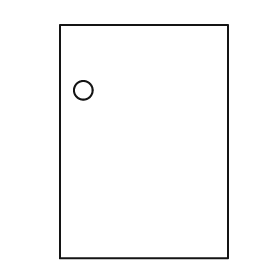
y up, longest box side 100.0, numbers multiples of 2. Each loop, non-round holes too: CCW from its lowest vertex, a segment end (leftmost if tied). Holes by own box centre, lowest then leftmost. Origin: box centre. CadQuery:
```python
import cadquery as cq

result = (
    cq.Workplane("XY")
    .moveTo(-36.0, -50.0)
    .lineTo(36.0, -50.0)
    .lineTo(36.0, 50.0)
    .lineTo(-36.0, 50.0)
    .close()
    .moveTo(-26.0, 22.0)
    .circle(4.0)
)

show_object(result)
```